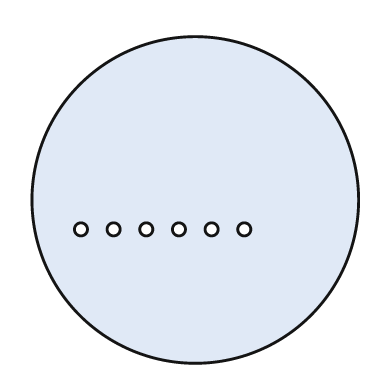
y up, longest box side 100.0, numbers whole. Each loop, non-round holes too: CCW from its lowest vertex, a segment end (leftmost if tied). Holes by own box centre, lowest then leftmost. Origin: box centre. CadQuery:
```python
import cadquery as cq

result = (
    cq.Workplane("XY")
    .moveTo(0.0, 0.0)
    .circle(50.0)
    .moveTo(-35.0, -9.0)
    .circle(2.0)
    .moveTo(-25.0, -9.0)
    .circle(2.0)
    .moveTo(-15.0, -9.0)
    .circle(2.0)
    .moveTo(-5.0, -9.0)
    .circle(2.0)
    .moveTo(5.0, -9.0)
    .circle(2.0)
    .moveTo(15.0, -9.0)
    .circle(2.0)
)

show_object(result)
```